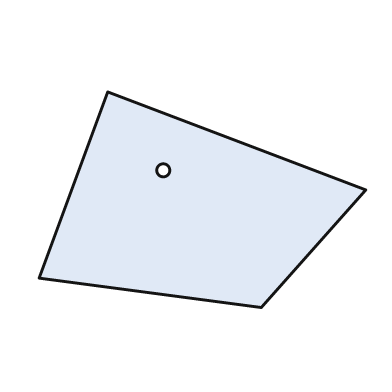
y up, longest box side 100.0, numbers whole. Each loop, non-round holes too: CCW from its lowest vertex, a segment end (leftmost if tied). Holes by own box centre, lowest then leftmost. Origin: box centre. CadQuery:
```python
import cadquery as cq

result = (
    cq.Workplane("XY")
    .moveTo(18.0, -33.0)
    .lineTo(50.0, 3.0)
    .lineTo(-29.0, 33.0)
    .lineTo(-50.0, -24.0)
    .close()
    .moveTo(-12.0, 9.0)
    .circle(2.0)
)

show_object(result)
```